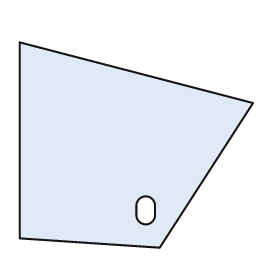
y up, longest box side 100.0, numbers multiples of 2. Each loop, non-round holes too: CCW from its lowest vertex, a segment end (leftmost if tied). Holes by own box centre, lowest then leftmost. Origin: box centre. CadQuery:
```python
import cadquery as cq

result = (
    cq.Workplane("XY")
    .moveTo(10.0, -44.0)
    .lineTo(50.0, 18.0)
    .lineTo(-50.0, 44.0)
    .lineTo(-50.0, -40.0)
    .close()
    .moveTo(0.0, -30.0)
    .threePointArc((4.0, -34.0), (8.0, -30.0))
    .lineTo(8.0, -26.0)
    .threePointArc((4.0, -22.0), (0.0, -26.0))
    .close()
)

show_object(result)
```